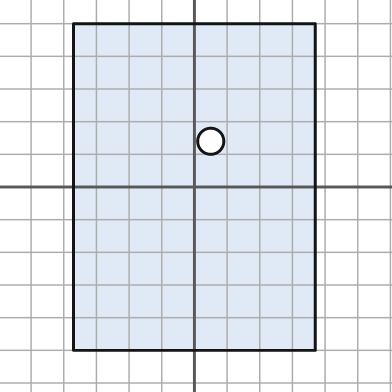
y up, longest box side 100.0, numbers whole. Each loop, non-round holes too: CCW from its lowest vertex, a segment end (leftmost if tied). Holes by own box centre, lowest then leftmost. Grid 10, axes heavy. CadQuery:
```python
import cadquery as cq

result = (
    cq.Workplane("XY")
    .moveTo(-37.0, -50.0)
    .lineTo(37.0, -50.0)
    .lineTo(37.0, 50.0)
    .lineTo(-37.0, 50.0)
    .close()
    .moveTo(5.0, 14.0)
    .circle(4.0)
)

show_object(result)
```